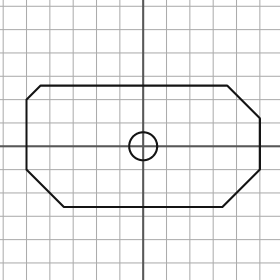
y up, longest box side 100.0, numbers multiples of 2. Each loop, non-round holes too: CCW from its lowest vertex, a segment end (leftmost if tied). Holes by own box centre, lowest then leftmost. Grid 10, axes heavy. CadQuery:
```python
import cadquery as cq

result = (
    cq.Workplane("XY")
    .moveTo(-34.0, -26.0)
    .lineTo(34.0, -26.0)
    .lineTo(50.0, -10.0)
    .lineTo(50.0, 12.0)
    .lineTo(36.0, 26.0)
    .lineTo(-44.0, 26.0)
    .lineTo(-50.0, 20.0)
    .lineTo(-50.0, -10.0)
    .close()
    .moveTo(0.0, 0.0)
    .circle(6.0)
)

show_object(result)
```